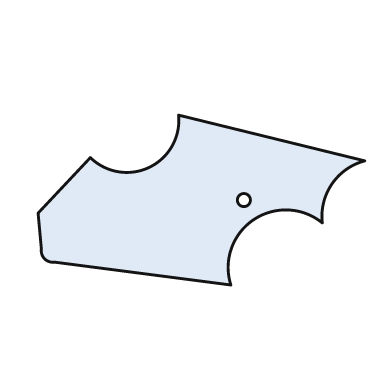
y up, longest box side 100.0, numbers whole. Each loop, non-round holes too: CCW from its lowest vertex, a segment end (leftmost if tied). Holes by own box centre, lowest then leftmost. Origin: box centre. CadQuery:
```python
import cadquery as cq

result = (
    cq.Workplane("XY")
    .moveTo(9.0, -26.0)
    .threePointArc((16.0, -6.0), (37.0, -7.0))
    .threePointArc((40.0, 5.0), (50.0, 12.0))
    .lineTo(-7.0, 26.0)
    .threePointArc((-16.0, 10.0), (-34.0, 13.0))
    .lineTo(-50.0, -4.0)
    .lineTo(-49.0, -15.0)
    .threePointArc((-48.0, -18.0), (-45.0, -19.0))
    .close()
    .moveTo(13.0, 0.0)
    .circle(2.0)
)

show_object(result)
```